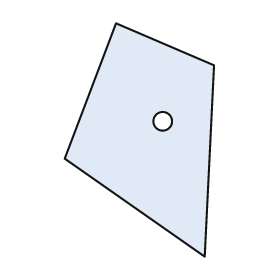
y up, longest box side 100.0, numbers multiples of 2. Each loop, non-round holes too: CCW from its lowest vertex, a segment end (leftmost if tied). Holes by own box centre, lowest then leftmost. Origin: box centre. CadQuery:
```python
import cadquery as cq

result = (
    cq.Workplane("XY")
    .moveTo(28.0, -50.0)
    .lineTo(32.0, 32.0)
    .lineTo(-10.0, 50.0)
    .lineTo(-32.0, -8.0)
    .close()
    .moveTo(10.0, 8.0)
    .circle(4.0)
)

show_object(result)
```